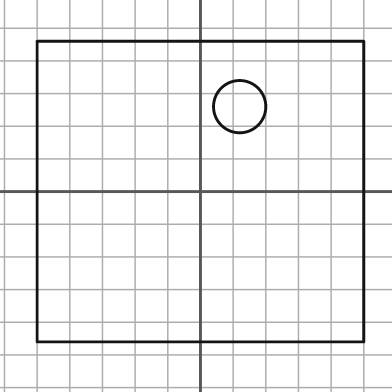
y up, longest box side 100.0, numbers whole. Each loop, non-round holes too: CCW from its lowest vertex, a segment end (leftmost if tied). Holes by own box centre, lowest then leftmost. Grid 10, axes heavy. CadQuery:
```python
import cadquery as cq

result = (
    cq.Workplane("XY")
    .moveTo(-50.0, -46.0)
    .lineTo(50.0, -46.0)
    .lineTo(50.0, 46.0)
    .lineTo(-50.0, 46.0)
    .close()
    .moveTo(12.0, 26.0)
    .circle(8.0)
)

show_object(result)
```